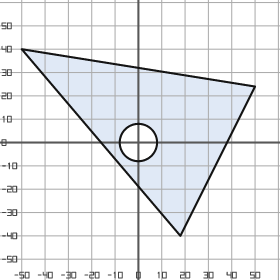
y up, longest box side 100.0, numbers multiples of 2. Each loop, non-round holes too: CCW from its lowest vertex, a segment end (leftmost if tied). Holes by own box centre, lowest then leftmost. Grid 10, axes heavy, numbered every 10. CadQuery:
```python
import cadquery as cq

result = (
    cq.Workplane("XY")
    .moveTo(18.0, -40.0)
    .lineTo(50.0, 24.0)
    .lineTo(-50.0, 40.0)
    .close()
    .moveTo(0.0, 0.0)
    .circle(8.0)
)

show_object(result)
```